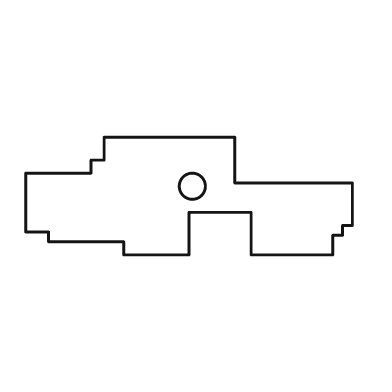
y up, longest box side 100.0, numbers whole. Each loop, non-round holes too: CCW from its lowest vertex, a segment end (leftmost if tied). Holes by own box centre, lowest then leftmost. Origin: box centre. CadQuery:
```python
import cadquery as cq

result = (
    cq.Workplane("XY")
    .moveTo(-20.0, -18.0)
    .lineTo(0.0, -18.0)
    .lineTo(0.0, -5.0)
    .lineTo(19.0, -5.0)
    .lineTo(19.0, -18.0)
    .lineTo(44.0, -18.0)
    .lineTo(44.0, -12.0)
    .lineTo(47.0, -12.0)
    .lineTo(47.0, -9.0)
    .lineTo(50.0, -9.0)
    .lineTo(50.0, 4.0)
    .lineTo(14.0, 4.0)
    .lineTo(14.0, 18.0)
    .lineTo(-26.0, 18.0)
    .lineTo(-26.0, 11.0)
    .lineTo(-30.0, 11.0)
    .lineTo(-30.0, 7.0)
    .lineTo(-50.0, 7.0)
    .lineTo(-50.0, -11.0)
    .lineTo(-43.0, -11.0)
    .lineTo(-43.0, -14.0)
    .lineTo(-20.0, -14.0)
    .close()
    .moveTo(1.0, 3.0)
    .circle(4.0)
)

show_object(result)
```